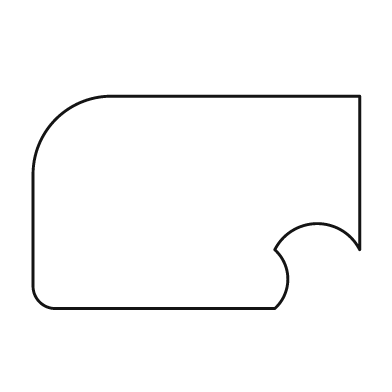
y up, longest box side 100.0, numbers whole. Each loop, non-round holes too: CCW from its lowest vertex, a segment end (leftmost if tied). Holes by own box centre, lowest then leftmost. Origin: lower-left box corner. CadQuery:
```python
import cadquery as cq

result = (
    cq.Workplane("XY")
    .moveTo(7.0, 0.0)
    .lineTo(74.0, 0.0)
    .threePointArc((78.0, 9.0), (74.0, 18.0))
    .threePointArc((87.0, 26.0), (100.0, 18.0))
    .lineTo(100.0, 65.0)
    .lineTo(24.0, 65.0)
    .threePointArc((7.0, 58.0), (0.0, 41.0))
    .lineTo(0.0, 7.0)
    .threePointArc((2.0, 2.0), (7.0, 0.0))
    .close()
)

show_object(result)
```